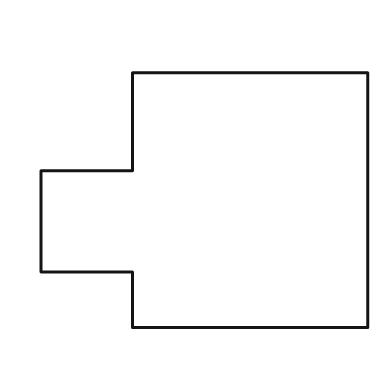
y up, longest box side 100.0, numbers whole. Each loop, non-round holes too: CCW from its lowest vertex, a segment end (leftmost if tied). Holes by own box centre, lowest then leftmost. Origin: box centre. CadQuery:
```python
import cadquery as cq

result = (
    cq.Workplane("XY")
    .moveTo(-22.0, -39.0)
    .lineTo(50.0, -39.0)
    .lineTo(50.0, 39.0)
    .lineTo(-22.0, 39.0)
    .lineTo(-22.0, 9.0)
    .lineTo(-50.0, 9.0)
    .lineTo(-50.0, -22.0)
    .lineTo(-22.0, -22.0)
    .close()
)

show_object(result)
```